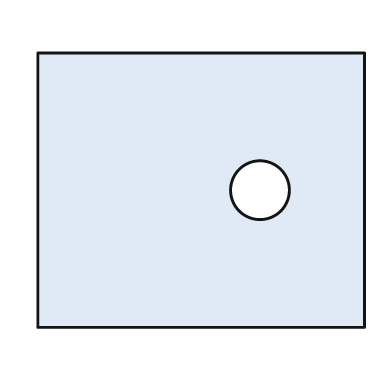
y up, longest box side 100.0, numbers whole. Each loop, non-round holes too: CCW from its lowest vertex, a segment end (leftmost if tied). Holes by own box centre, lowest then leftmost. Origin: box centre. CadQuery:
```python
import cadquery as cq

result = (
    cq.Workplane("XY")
    .moveTo(-50.0, -42.0)
    .lineTo(50.0, -42.0)
    .lineTo(50.0, 42.0)
    .lineTo(-50.0, 42.0)
    .close()
    .moveTo(18.0, 0.0)
    .circle(9.0)
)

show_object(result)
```